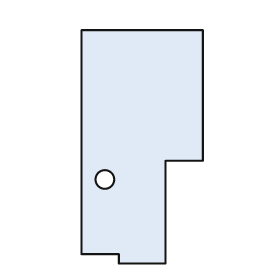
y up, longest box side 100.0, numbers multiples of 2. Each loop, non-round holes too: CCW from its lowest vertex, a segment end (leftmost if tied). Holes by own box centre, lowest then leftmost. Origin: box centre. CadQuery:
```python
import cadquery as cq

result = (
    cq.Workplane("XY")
    .moveTo(-10.0, -50.0)
    .lineTo(10.0, -50.0)
    .lineTo(10.0, -6.0)
    .lineTo(26.0, -6.0)
    .lineTo(26.0, 50.0)
    .lineTo(-26.0, 50.0)
    .lineTo(-26.0, -46.0)
    .lineTo(-10.0, -46.0)
    .close()
    .moveTo(-16.0, -14.0)
    .circle(4.0)
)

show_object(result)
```